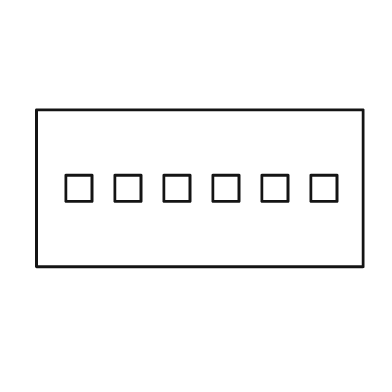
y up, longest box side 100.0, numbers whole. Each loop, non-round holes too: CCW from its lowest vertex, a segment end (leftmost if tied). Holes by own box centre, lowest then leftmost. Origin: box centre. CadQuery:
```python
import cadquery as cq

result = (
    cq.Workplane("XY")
    .moveTo(-50.0, -24.0)
    .lineTo(50.0, -24.0)
    .lineTo(50.0, 24.0)
    .lineTo(-50.0, 24.0)
    .close()
    .moveTo(-41.0, -4.0)
    .lineTo(-33.0, -4.0)
    .lineTo(-33.0, 4.0)
    .lineTo(-41.0, 4.0)
    .close()
    .moveTo(-26.0, -4.0)
    .lineTo(-18.0, -4.0)
    .lineTo(-18.0, 4.0)
    .lineTo(-26.0, 4.0)
    .close()
    .moveTo(-11.0, -4.0)
    .lineTo(-3.0, -4.0)
    .lineTo(-3.0, 4.0)
    .lineTo(-11.0, 4.0)
    .close()
    .moveTo(4.0, -4.0)
    .lineTo(12.0, -4.0)
    .lineTo(12.0, 4.0)
    .lineTo(4.0, 4.0)
    .close()
    .moveTo(19.0, -4.0)
    .lineTo(27.0, -4.0)
    .lineTo(27.0, 4.0)
    .lineTo(19.0, 4.0)
    .close()
    .moveTo(34.0, -4.0)
    .lineTo(42.0, -4.0)
    .lineTo(42.0, 4.0)
    .lineTo(34.0, 4.0)
    .close()
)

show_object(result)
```